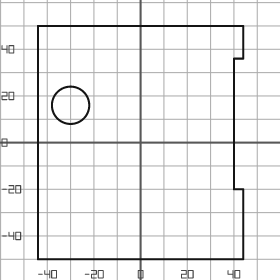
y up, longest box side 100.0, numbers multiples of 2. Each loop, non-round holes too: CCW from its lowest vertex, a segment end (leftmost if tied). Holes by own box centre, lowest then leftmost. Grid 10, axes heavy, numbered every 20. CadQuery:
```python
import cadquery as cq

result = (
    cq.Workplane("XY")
    .moveTo(-44.0, -50.0)
    .lineTo(44.0, -50.0)
    .lineTo(44.0, -20.0)
    .lineTo(40.0, -20.0)
    .lineTo(40.0, 36.0)
    .lineTo(44.0, 36.0)
    .lineTo(44.0, 50.0)
    .lineTo(-44.0, 50.0)
    .close()
    .moveTo(-30.0, 16.0)
    .circle(8.0)
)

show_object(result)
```